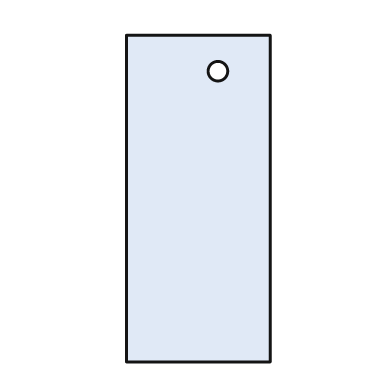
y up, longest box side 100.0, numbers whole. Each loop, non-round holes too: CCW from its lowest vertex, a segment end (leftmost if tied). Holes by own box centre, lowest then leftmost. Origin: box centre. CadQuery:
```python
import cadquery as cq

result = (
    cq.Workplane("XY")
    .moveTo(-22.0, -50.0)
    .lineTo(22.0, -50.0)
    .lineTo(22.0, 50.0)
    .lineTo(-22.0, 50.0)
    .close()
    .moveTo(6.0, 39.0)
    .circle(3.0)
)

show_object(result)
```